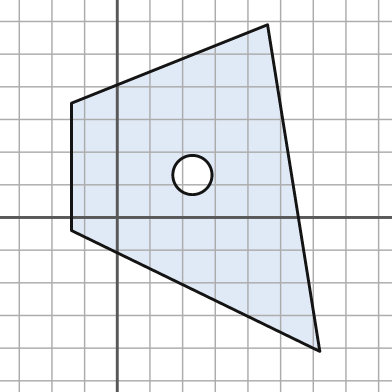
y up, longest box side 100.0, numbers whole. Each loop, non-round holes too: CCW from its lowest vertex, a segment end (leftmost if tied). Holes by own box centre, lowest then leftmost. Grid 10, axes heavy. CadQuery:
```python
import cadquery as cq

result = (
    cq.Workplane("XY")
    .moveTo(62.0, -41.0)
    .lineTo(46.0, 59.0)
    .lineTo(-14.0, 35.0)
    .lineTo(-14.0, -4.0)
    .close()
    .moveTo(23.0, 13.0)
    .circle(6.0)
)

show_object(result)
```